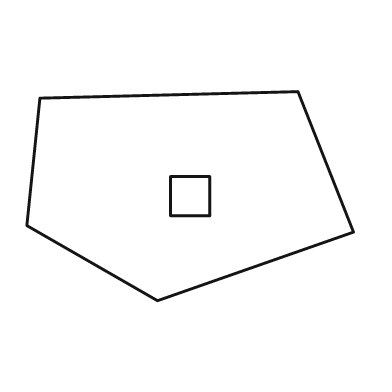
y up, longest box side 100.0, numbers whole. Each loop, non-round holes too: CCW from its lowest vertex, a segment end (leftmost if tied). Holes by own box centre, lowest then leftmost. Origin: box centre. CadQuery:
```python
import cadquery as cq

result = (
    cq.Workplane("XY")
    .moveTo(-10.0, -32.0)
    .lineTo(50.0, -11.0)
    .lineTo(33.0, 32.0)
    .lineTo(-46.0, 30.0)
    .lineTo(-50.0, -9.0)
    .close()
    .moveTo(-6.0, -6.0)
    .lineTo(6.0, -6.0)
    .lineTo(6.0, 6.0)
    .lineTo(-6.0, 6.0)
    .close()
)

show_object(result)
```